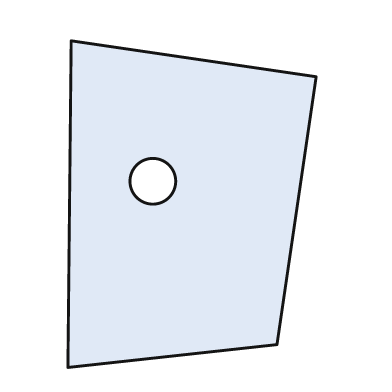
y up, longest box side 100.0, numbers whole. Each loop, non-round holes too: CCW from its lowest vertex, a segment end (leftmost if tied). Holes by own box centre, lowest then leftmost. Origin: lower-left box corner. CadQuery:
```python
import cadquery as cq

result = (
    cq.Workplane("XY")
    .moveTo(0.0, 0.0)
    .lineTo(64.0, 7.0)
    .lineTo(76.0, 89.0)
    .lineTo(1.0, 100.0)
    .close()
    .moveTo(26.0, 57.0)
    .circle(7.0)
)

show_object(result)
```